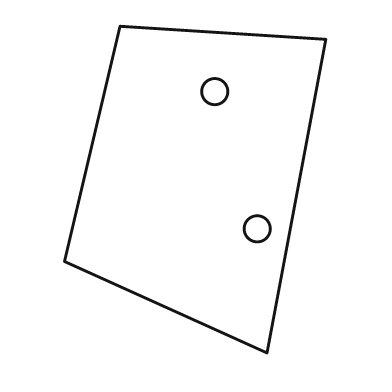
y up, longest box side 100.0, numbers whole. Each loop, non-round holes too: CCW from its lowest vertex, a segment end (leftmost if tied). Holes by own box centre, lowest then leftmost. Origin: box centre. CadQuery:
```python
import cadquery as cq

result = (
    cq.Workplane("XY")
    .moveTo(22.0, -50.0)
    .lineTo(40.0, 46.0)
    .lineTo(-23.0, 50.0)
    .lineTo(-40.0, -22.0)
    .close()
    .moveTo(19.0, -12.0)
    .circle(4.0)
    .moveTo(6.0, 30.0)
    .circle(4.0)
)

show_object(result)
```